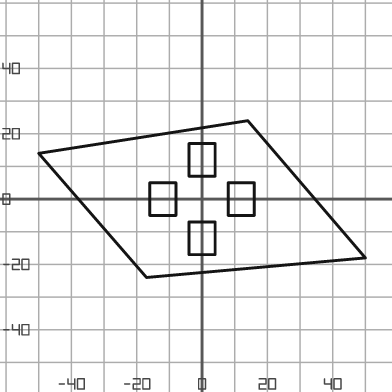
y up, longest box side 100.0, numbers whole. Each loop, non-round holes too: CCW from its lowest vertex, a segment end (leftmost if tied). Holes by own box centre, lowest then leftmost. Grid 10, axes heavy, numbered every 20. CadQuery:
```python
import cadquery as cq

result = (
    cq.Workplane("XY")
    .moveTo(-17.0, -24.0)
    .lineTo(50.0, -18.0)
    .lineTo(14.0, 24.0)
    .lineTo(-50.0, 14.0)
    .close()
    .moveTo(-4.0, -17.0)
    .lineTo(4.0, -17.0)
    .lineTo(4.0, -7.0)
    .lineTo(-4.0, -7.0)
    .close()
    .moveTo(-16.0, -5.0)
    .lineTo(-8.0, -5.0)
    .lineTo(-8.0, 5.0)
    .lineTo(-16.0, 5.0)
    .close()
    .moveTo(8.0, -5.0)
    .lineTo(16.0, -5.0)
    .lineTo(16.0, 5.0)
    .lineTo(8.0, 5.0)
    .close()
    .moveTo(-4.0, 7.0)
    .lineTo(4.0, 7.0)
    .lineTo(4.0, 17.0)
    .lineTo(-4.0, 17.0)
    .close()
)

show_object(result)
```